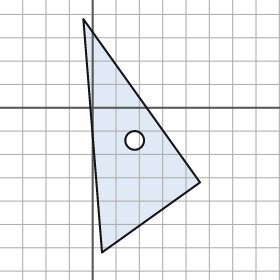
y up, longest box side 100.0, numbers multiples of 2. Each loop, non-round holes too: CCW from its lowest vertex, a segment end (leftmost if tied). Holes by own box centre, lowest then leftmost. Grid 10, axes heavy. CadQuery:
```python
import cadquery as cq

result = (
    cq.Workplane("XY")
    .moveTo(4.0, -62.0)
    .lineTo(46.0, -32.0)
    .lineTo(-4.0, 38.0)
    .close()
    .moveTo(18.0, -14.0)
    .circle(4.0)
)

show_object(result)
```